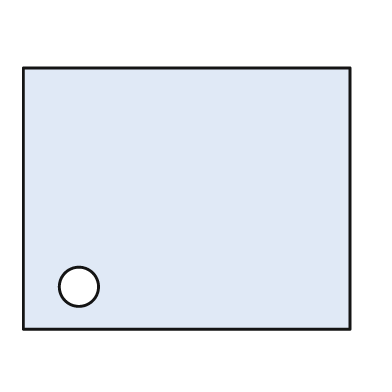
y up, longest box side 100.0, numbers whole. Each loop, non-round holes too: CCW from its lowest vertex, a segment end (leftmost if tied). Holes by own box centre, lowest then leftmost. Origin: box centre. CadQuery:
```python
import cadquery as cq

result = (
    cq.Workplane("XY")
    .moveTo(-50.0, -40.0)
    .lineTo(50.0, -40.0)
    .lineTo(50.0, 40.0)
    .lineTo(-50.0, 40.0)
    .close()
    .moveTo(-33.0, -27.0)
    .circle(6.0)
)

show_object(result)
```